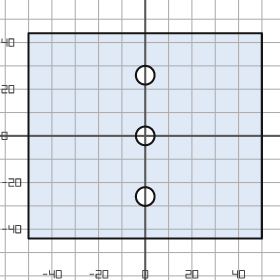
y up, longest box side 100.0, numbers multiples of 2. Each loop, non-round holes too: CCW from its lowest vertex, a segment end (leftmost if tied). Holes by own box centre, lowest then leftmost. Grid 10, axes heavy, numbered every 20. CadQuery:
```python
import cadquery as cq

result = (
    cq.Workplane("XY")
    .moveTo(-50.0, -44.0)
    .lineTo(50.0, -44.0)
    .lineTo(50.0, 44.0)
    .lineTo(-50.0, 44.0)
    .close()
    .moveTo(0.0, -26.0)
    .circle(4.0)
    .moveTo(0.0, 0.0)
    .circle(4.0)
    .moveTo(0.0, 26.0)
    .circle(4.0)
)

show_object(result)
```